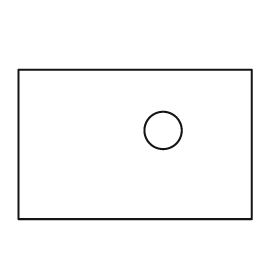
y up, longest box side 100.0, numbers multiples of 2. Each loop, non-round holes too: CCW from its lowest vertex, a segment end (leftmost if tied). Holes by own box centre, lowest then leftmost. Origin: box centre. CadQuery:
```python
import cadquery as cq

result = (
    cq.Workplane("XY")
    .moveTo(-50.0, -32.0)
    .lineTo(50.0, -32.0)
    .lineTo(50.0, 32.0)
    .lineTo(-50.0, 32.0)
    .close()
    .moveTo(12.0, 6.0)
    .circle(8.0)
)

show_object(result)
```